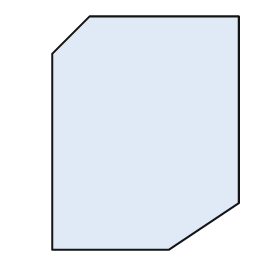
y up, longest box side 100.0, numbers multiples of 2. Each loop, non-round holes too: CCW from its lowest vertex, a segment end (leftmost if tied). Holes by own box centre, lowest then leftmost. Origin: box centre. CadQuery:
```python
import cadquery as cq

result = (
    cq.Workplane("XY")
    .moveTo(-40.0, -50.0)
    .lineTo(10.0, -50.0)
    .lineTo(40.0, -30.0)
    .lineTo(40.0, 50.0)
    .lineTo(-24.0, 50.0)
    .lineTo(-40.0, 34.0)
    .close()
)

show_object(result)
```